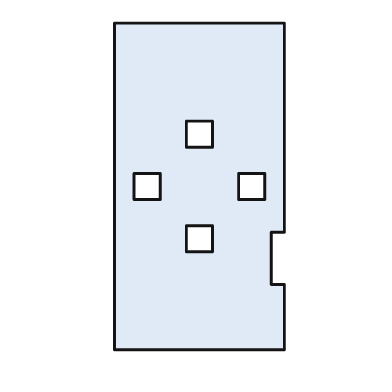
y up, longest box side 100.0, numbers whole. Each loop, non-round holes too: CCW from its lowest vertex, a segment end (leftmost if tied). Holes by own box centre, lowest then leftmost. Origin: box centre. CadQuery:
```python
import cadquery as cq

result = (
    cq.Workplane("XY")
    .moveTo(-26.0, -50.0)
    .lineTo(26.0, -50.0)
    .lineTo(26.0, -30.0)
    .lineTo(22.0, -30.0)
    .lineTo(22.0, -14.0)
    .lineTo(26.0, -14.0)
    .lineTo(26.0, 50.0)
    .lineTo(-26.0, 50.0)
    .close()
    .moveTo(-4.0, -20.0)
    .lineTo(4.0, -20.0)
    .lineTo(4.0, -12.0)
    .lineTo(-4.0, -12.0)
    .close()
    .moveTo(-20.0, -4.0)
    .lineTo(-12.0, -4.0)
    .lineTo(-12.0, 4.0)
    .lineTo(-20.0, 4.0)
    .close()
    .moveTo(12.0, -4.0)
    .lineTo(20.0, -4.0)
    .lineTo(20.0, 4.0)
    .lineTo(12.0, 4.0)
    .close()
    .moveTo(-4.0, 12.0)
    .lineTo(4.0, 12.0)
    .lineTo(4.0, 20.0)
    .lineTo(-4.0, 20.0)
    .close()
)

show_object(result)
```